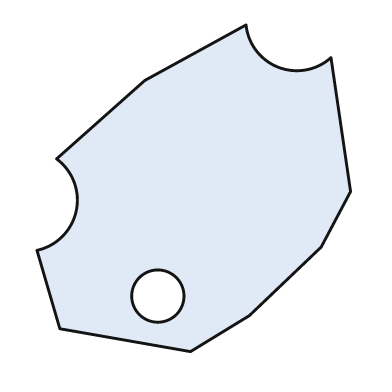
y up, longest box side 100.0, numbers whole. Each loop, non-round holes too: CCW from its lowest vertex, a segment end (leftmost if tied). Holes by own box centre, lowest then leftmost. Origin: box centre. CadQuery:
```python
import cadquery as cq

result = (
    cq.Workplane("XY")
    .moveTo(-1.0, -50.0)
    .lineTo(17.0, -39.0)
    .lineTo(39.0, -18.0)
    .lineTo(48.0, -1.0)
    .lineTo(42.0, 40.0)
    .threePointArc((26.0, 37.0), (16.0, 50.0))
    .lineTo(-15.0, 33.0)
    .lineTo(-42.0, 9.0)
    .threePointArc((-36.0, -7.0), (-48.0, -19.0))
    .lineTo(-41.0, -43.0)
    .close()
    .moveTo(-11.0, -33.0)
    .circle(8.0)
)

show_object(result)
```